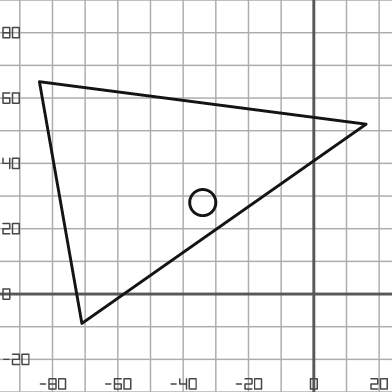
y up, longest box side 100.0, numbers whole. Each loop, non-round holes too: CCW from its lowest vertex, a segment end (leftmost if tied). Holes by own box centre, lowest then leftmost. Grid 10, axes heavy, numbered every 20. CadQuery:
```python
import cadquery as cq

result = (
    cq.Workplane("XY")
    .moveTo(-71.0, -9.0)
    .lineTo(16.0, 52.0)
    .lineTo(-84.0, 65.0)
    .close()
    .moveTo(-34.0, 28.0)
    .circle(4.0)
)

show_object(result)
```